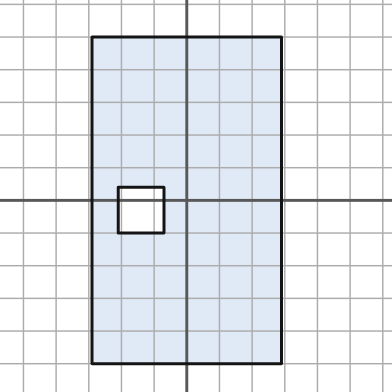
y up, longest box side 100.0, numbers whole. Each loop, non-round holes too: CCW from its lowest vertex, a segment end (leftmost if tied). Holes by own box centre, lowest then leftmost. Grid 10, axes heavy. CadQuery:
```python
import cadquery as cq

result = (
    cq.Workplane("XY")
    .moveTo(-29.0, -50.0)
    .lineTo(29.0, -50.0)
    .lineTo(29.0, 50.0)
    .lineTo(-29.0, 50.0)
    .close()
    .moveTo(-21.0, -10.0)
    .lineTo(-7.0, -10.0)
    .lineTo(-7.0, 4.0)
    .lineTo(-21.0, 4.0)
    .close()
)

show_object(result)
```